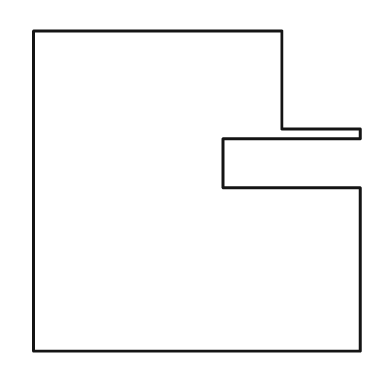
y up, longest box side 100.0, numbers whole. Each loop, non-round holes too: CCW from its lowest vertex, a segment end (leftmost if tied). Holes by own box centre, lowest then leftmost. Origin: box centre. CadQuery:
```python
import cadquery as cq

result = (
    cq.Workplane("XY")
    .moveTo(-50.0, -49.0)
    .lineTo(50.0, -49.0)
    .lineTo(50.0, 1.0)
    .lineTo(8.0, 1.0)
    .lineTo(8.0, 16.0)
    .lineTo(50.0, 16.0)
    .lineTo(50.0, 19.0)
    .lineTo(26.0, 19.0)
    .lineTo(26.0, 49.0)
    .lineTo(-50.0, 49.0)
    .close()
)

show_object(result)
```